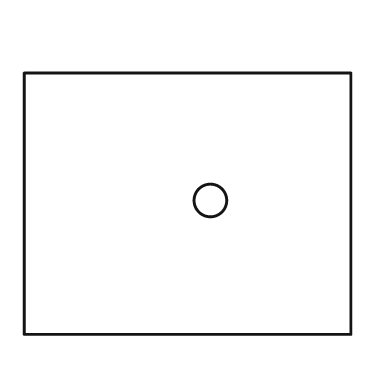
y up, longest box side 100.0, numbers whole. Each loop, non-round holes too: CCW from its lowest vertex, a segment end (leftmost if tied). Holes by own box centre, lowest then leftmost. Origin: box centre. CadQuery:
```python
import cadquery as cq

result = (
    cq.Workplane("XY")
    .moveTo(-50.0, -40.0)
    .lineTo(50.0, -40.0)
    .lineTo(50.0, 40.0)
    .lineTo(-50.0, 40.0)
    .close()
    .moveTo(7.0, 1.0)
    .circle(5.0)
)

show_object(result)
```